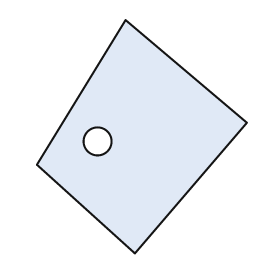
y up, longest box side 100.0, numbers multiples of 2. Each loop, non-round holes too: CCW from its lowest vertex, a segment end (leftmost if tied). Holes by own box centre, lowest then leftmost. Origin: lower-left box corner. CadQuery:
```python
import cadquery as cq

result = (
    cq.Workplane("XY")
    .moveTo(42.0, 0.0)
    .lineTo(90.0, 56.0)
    .lineTo(38.0, 100.0)
    .lineTo(0.0, 38.0)
    .close()
    .moveTo(26.0, 48.0)
    .circle(6.0)
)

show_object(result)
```